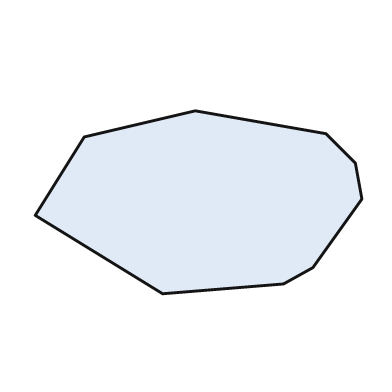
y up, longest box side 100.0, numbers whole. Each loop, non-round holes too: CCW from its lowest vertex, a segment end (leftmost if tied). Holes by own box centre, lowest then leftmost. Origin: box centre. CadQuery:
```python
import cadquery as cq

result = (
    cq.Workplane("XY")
    .moveTo(-11.0, -28.0)
    .lineTo(26.0, -25.0)
    .lineTo(35.0, -20.0)
    .lineTo(50.0, 1.0)
    .lineTo(48.0, 12.0)
    .lineTo(39.0, 21.0)
    .lineTo(-1.0, 28.0)
    .lineTo(-35.0, 20.0)
    .lineTo(-50.0, -4.0)
    .close()
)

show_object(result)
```